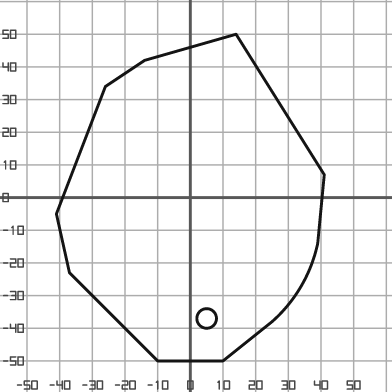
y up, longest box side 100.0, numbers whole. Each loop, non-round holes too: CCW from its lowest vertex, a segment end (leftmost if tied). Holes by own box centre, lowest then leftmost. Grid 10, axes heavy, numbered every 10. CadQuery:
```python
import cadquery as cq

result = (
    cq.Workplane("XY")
    .moveTo(-10.0, -50.0)
    .lineTo(10.0, -50.0)
    .lineTo(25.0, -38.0)
    .threePointArc((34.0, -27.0), (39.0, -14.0))
    .lineTo(41.0, 7.0)
    .lineTo(14.0, 50.0)
    .lineTo(-14.0, 42.0)
    .lineTo(-26.0, 34.0)
    .lineTo(-41.0, -5.0)
    .lineTo(-37.0, -23.0)
    .close()
    .moveTo(5.0, -37.0)
    .circle(3.0)
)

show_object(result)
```